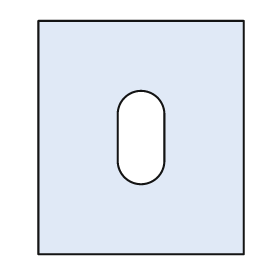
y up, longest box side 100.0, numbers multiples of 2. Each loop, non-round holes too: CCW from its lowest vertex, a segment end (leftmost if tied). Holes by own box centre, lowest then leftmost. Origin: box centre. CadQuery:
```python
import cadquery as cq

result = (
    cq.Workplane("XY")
    .moveTo(-44.0, -50.0)
    .lineTo(44.0, -50.0)
    .lineTo(44.0, 50.0)
    .lineTo(-44.0, 50.0)
    .close()
    .moveTo(-10.0, -10.0)
    .threePointArc((0.0, -20.0), (10.0, -10.0))
    .lineTo(10.0, 10.0)
    .threePointArc((0.0, 20.0), (-10.0, 10.0))
    .close()
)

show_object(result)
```